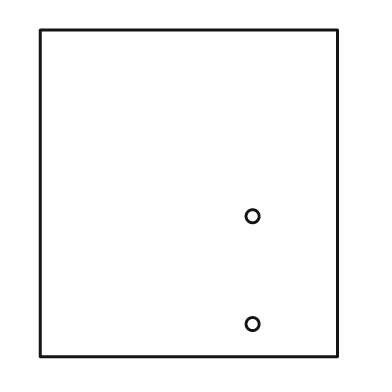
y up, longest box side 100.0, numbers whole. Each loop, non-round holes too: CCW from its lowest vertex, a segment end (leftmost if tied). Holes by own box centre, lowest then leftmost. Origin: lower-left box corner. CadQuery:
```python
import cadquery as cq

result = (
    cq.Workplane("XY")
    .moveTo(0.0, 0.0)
    .lineTo(91.0, 0.0)
    .lineTo(91.0, 100.0)
    .lineTo(0.0, 100.0)
    .close()
    .moveTo(65.0, 10.0)
    .circle(2.0)
    .moveTo(65.0, 43.0)
    .circle(2.0)
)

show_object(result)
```